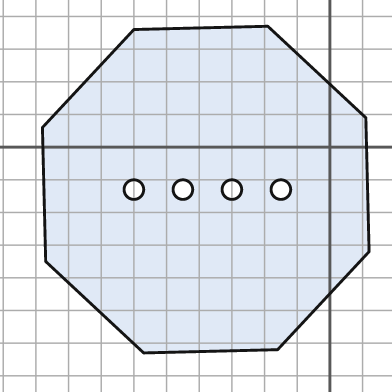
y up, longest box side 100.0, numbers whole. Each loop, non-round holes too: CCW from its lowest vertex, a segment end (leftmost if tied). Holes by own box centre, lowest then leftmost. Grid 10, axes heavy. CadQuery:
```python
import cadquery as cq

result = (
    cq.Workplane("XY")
    .moveTo(-57.0, -63.0)
    .lineTo(-16.0, -62.0)
    .lineTo(12.0, -32.0)
    .lineTo(11.0, 9.0)
    .lineTo(-19.0, 37.0)
    .lineTo(-60.0, 36.0)
    .lineTo(-88.0, 6.0)
    .lineTo(-87.0, -35.0)
    .close()
    .moveTo(-60.0, -13.0)
    .circle(3.0)
    .moveTo(-45.0, -13.0)
    .circle(3.0)
    .moveTo(-30.0, -13.0)
    .circle(3.0)
    .moveTo(-15.0, -13.0)
    .circle(3.0)
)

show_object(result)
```